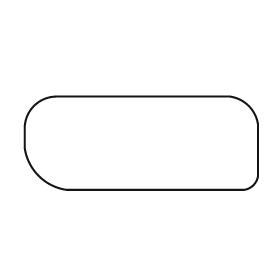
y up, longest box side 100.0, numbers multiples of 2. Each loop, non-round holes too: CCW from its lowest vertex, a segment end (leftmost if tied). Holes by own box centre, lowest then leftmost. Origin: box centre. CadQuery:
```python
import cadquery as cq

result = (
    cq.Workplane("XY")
    .moveTo(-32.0, -20.0)
    .lineTo(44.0, -20.0)
    .threePointArc((48.0, -18.0), (50.0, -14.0))
    .lineTo(50.0, 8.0)
    .threePointArc((46.0, 16.0), (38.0, 20.0))
    .lineTo(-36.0, 20.0)
    .threePointArc((-46.0, 16.0), (-50.0, 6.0))
    .lineTo(-50.0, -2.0)
    .threePointArc((-44.0, -14.0), (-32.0, -20.0))
    .close()
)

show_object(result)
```